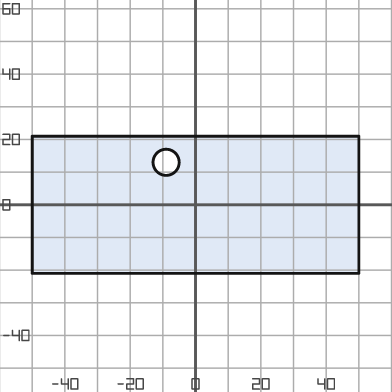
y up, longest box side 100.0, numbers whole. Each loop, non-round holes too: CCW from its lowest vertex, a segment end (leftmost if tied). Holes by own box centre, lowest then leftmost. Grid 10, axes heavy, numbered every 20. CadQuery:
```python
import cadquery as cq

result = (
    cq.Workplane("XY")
    .moveTo(-50.0, -21.0)
    .lineTo(50.0, -21.0)
    .lineTo(50.0, 21.0)
    .lineTo(-50.0, 21.0)
    .close()
    .moveTo(-9.0, 13.0)
    .circle(4.0)
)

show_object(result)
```